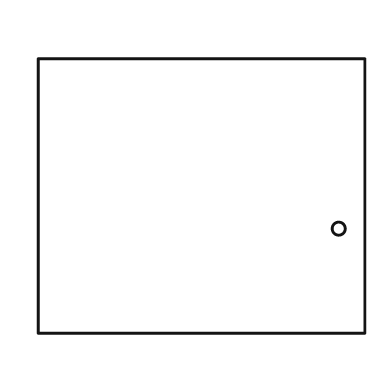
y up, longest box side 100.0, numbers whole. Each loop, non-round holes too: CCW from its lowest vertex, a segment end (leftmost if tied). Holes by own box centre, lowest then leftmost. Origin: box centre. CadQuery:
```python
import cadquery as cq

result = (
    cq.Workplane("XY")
    .moveTo(-50.0, -42.0)
    .lineTo(50.0, -42.0)
    .lineTo(50.0, 42.0)
    .lineTo(-50.0, 42.0)
    .close()
    .moveTo(42.0, -10.0)
    .circle(2.0)
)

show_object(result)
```